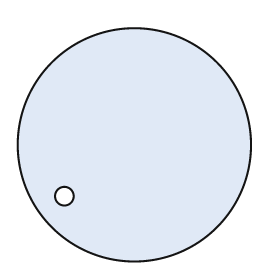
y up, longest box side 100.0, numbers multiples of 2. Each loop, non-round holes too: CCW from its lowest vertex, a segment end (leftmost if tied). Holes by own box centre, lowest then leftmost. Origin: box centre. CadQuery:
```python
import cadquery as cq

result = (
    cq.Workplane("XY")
    .moveTo(0.0, 0.0)
    .circle(50.0)
    .moveTo(-30.0, -22.0)
    .circle(4.0)
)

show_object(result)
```